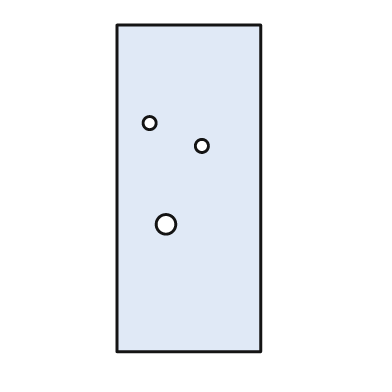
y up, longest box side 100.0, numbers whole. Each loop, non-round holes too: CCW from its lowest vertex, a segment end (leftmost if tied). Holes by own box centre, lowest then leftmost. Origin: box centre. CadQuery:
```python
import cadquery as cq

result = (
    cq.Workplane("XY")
    .moveTo(-22.0, -50.0)
    .lineTo(22.0, -50.0)
    .lineTo(22.0, 50.0)
    .lineTo(-22.0, 50.0)
    .close()
    .moveTo(-7.0, -11.0)
    .circle(3.0)
    .moveTo(4.0, 13.0)
    .circle(2.0)
    .moveTo(-12.0, 20.0)
    .circle(2.0)
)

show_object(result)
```